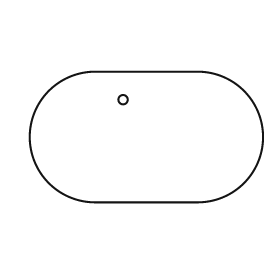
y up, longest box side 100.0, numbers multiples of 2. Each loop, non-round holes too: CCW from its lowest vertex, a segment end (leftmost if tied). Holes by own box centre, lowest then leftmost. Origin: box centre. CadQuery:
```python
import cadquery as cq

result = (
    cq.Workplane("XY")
    .moveTo(-22.0, -28.0)
    .lineTo(22.0, -28.0)
    .threePointArc((50.0, 0.0), (22.0, 28.0))
    .lineTo(-22.0, 28.0)
    .threePointArc((-50.0, 0.0), (-22.0, -28.0))
    .close()
    .moveTo(-10.0, 16.0)
    .circle(2.0)
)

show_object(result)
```